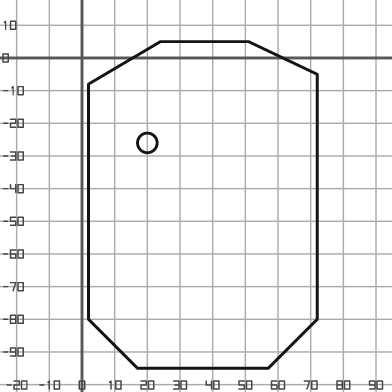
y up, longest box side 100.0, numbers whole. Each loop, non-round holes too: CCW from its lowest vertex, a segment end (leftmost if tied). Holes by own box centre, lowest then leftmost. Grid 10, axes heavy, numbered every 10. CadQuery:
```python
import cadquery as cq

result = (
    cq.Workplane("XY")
    .moveTo(17.0, -95.0)
    .lineTo(57.0, -95.0)
    .lineTo(72.0, -80.0)
    .lineTo(72.0, -5.0)
    .lineTo(51.0, 5.0)
    .lineTo(24.0, 5.0)
    .lineTo(2.0, -8.0)
    .lineTo(2.0, -80.0)
    .close()
    .moveTo(20.0, -26.0)
    .circle(3.0)
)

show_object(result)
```